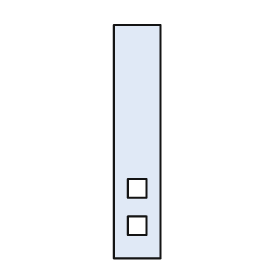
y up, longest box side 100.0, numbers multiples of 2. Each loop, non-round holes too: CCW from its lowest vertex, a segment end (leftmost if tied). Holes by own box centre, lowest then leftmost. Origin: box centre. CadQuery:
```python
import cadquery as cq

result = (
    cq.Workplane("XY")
    .moveTo(-10.0, -50.0)
    .lineTo(10.0, -50.0)
    .lineTo(10.0, 50.0)
    .lineTo(-10.0, 50.0)
    .close()
    .moveTo(-4.0, -40.0)
    .lineTo(4.0, -40.0)
    .lineTo(4.0, -32.0)
    .lineTo(-4.0, -32.0)
    .close()
    .moveTo(-4.0, -24.0)
    .lineTo(4.0, -24.0)
    .lineTo(4.0, -16.0)
    .lineTo(-4.0, -16.0)
    .close()
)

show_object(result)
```